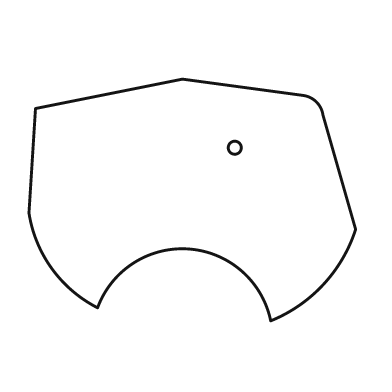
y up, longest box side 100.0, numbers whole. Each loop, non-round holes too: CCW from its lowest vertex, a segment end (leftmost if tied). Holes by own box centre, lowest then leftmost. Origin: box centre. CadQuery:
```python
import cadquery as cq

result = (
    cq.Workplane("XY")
    .moveTo(24.0, -37.0)
    .threePointArc((40.0, -26.0), (50.0, -9.0))
    .lineTo(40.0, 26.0)
    .threePointArc((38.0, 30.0), (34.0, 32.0))
    .lineTo(-3.0, 37.0)
    .lineTo(-48.0, 28.0)
    .lineTo(-50.0, -4.0)
    .threePointArc((-43.0, -21.0), (-29.0, -33.0))
    .threePointArc((-1.0, -15.0), (24.0, -37.0))
    .close()
    .moveTo(13.0, 16.0)
    .circle(2.0)
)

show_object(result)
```